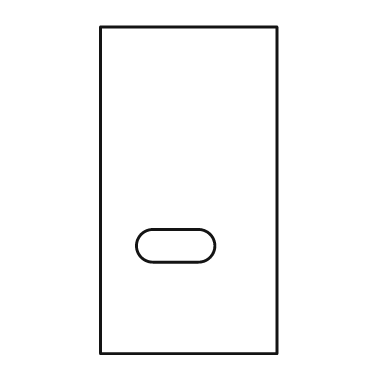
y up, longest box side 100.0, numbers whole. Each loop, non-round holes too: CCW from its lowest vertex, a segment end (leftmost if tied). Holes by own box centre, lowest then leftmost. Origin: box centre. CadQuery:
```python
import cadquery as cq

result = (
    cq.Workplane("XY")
    .moveTo(-27.0, -50.0)
    .lineTo(27.0, -50.0)
    .lineTo(27.0, 50.0)
    .lineTo(-27.0, 50.0)
    .close()
    .moveTo(-11.0, -22.0)
    .lineTo(3.0, -22.0)
    .threePointArc((8.0, -17.0), (3.0, -12.0))
    .lineTo(-11.0, -12.0)
    .threePointArc((-16.0, -17.0), (-11.0, -22.0))
    .close()
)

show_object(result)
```